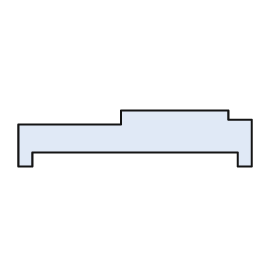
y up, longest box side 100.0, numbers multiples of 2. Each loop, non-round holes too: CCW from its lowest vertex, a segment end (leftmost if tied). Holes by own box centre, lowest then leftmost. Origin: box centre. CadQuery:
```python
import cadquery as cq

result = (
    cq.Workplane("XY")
    .moveTo(-50.0, -12.0)
    .lineTo(-44.0, -12.0)
    .lineTo(-44.0, -6.0)
    .lineTo(44.0, -6.0)
    .lineTo(44.0, -12.0)
    .lineTo(50.0, -12.0)
    .lineTo(50.0, 8.0)
    .lineTo(40.0, 8.0)
    .lineTo(40.0, 12.0)
    .lineTo(-6.0, 12.0)
    .lineTo(-6.0, 6.0)
    .lineTo(-50.0, 6.0)
    .close()
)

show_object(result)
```